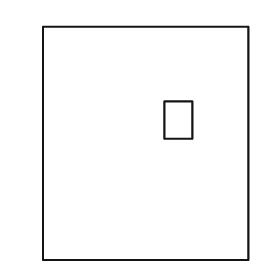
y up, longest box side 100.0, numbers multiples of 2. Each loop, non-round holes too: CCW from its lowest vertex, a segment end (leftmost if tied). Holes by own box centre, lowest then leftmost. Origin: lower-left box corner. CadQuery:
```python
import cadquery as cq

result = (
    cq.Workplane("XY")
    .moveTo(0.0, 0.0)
    .lineTo(88.0, 0.0)
    .lineTo(88.0, 100.0)
    .lineTo(0.0, 100.0)
    .close()
    .moveTo(52.0, 52.0)
    .lineTo(64.0, 52.0)
    .lineTo(64.0, 68.0)
    .lineTo(52.0, 68.0)
    .close()
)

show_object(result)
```